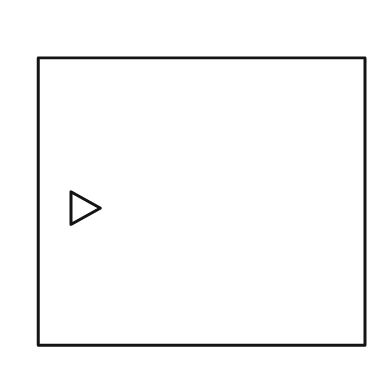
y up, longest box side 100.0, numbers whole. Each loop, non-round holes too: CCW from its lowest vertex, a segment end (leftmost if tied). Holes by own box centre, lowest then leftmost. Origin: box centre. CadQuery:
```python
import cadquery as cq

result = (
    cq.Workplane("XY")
    .moveTo(-50.0, -44.0)
    .lineTo(50.0, -44.0)
    .lineTo(50.0, 44.0)
    .lineTo(-50.0, 44.0)
    .close()
    .moveTo(-40.0, -7.0)
    .lineTo(-31.0, -2.0)
    .lineTo(-40.0, 3.0)
    .close()
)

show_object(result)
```